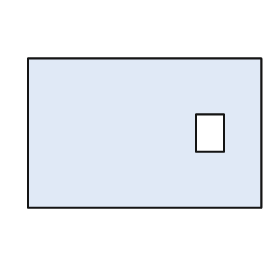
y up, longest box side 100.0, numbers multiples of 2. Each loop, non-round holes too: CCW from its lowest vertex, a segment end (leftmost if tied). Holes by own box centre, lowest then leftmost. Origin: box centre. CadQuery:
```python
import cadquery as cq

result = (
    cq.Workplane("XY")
    .moveTo(-50.0, -32.0)
    .lineTo(50.0, -32.0)
    .lineTo(50.0, 32.0)
    .lineTo(-50.0, 32.0)
    .close()
    .moveTo(22.0, -8.0)
    .lineTo(34.0, -8.0)
    .lineTo(34.0, 8.0)
    .lineTo(22.0, 8.0)
    .close()
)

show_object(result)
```